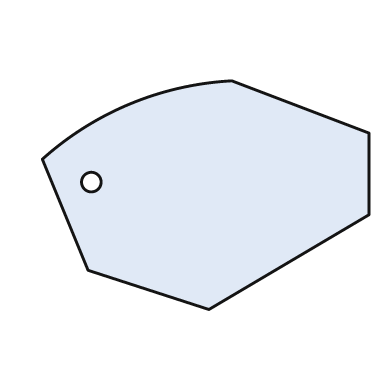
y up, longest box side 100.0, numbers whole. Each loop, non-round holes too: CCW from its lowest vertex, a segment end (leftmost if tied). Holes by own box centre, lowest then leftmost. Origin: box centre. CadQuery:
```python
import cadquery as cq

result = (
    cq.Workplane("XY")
    .moveTo(1.0, -35.0)
    .lineTo(50.0, -6.0)
    .lineTo(50.0, 19.0)
    .lineTo(8.0, 35.0)
    .threePointArc((-23.0, 28.0), (-50.0, 11.0))
    .lineTo(-36.0, -23.0)
    .close()
    .moveTo(-35.0, 4.0)
    .circle(3.0)
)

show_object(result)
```